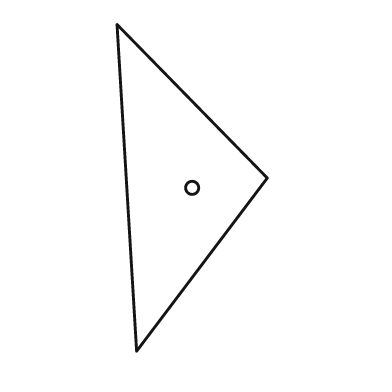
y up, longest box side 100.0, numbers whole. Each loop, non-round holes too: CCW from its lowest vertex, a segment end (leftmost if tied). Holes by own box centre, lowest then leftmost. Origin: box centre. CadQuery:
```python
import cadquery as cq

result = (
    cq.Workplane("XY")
    .moveTo(-17.0, -50.0)
    .lineTo(23.0, 3.0)
    .lineTo(-23.0, 50.0)
    .close()
    .moveTo(0.0, 0.0)
    .circle(2.0)
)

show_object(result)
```